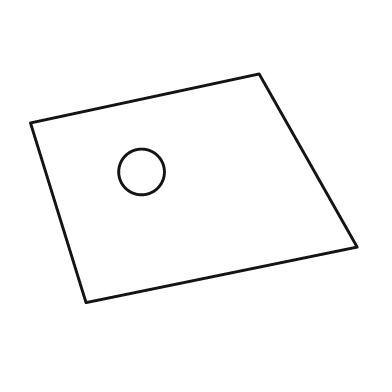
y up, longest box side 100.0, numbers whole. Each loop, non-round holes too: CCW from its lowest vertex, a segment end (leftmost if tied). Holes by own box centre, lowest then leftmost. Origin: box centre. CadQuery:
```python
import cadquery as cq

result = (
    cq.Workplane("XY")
    .moveTo(-33.0, -35.0)
    .lineTo(50.0, -18.0)
    .lineTo(20.0, 35.0)
    .lineTo(-50.0, 20.0)
    .close()
    .moveTo(-16.0, 5.0)
    .circle(7.0)
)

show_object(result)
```